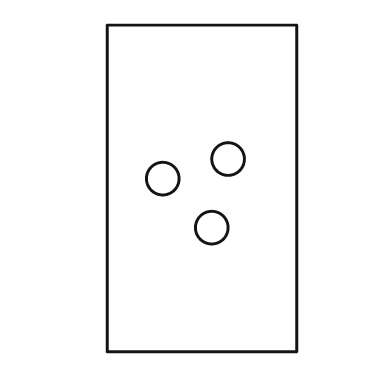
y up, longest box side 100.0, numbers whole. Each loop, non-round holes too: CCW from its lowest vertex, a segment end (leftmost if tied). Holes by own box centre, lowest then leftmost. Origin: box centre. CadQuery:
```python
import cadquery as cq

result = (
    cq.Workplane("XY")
    .moveTo(-29.0, -50.0)
    .lineTo(29.0, -50.0)
    .lineTo(29.0, 50.0)
    .lineTo(-29.0, 50.0)
    .close()
    .moveTo(3.0, -12.0)
    .circle(5.0)
    .moveTo(-12.0, 3.0)
    .circle(5.0)
    .moveTo(8.0, 9.0)
    .circle(5.0)
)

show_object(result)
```